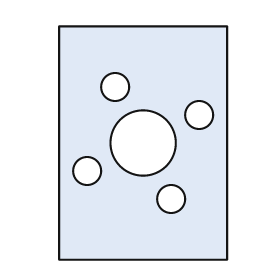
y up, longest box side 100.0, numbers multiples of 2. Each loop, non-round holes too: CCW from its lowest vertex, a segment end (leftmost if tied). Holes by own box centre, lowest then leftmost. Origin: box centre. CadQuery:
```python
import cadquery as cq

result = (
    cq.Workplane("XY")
    .moveTo(-36.0, -50.0)
    .lineTo(36.0, -50.0)
    .lineTo(36.0, 50.0)
    .lineTo(-36.0, 50.0)
    .close()
    .moveTo(12.0, -24.0)
    .circle(6.0)
    .moveTo(-24.0, -12.0)
    .circle(6.0)
    .moveTo(0.0, 0.0)
    .circle(14.0)
    .moveTo(24.0, 12.0)
    .circle(6.0)
    .moveTo(-12.0, 24.0)
    .circle(6.0)
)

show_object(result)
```